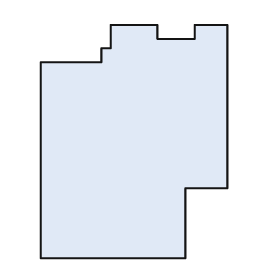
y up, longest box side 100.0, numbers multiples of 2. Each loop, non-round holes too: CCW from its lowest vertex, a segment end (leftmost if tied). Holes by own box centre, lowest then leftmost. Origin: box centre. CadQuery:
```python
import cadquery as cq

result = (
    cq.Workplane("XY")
    .moveTo(-40.0, -50.0)
    .lineTo(22.0, -50.0)
    .lineTo(22.0, -20.0)
    .lineTo(40.0, -20.0)
    .lineTo(40.0, 50.0)
    .lineTo(26.0, 50.0)
    .lineTo(26.0, 44.0)
    .lineTo(10.0, 44.0)
    .lineTo(10.0, 50.0)
    .lineTo(-10.0, 50.0)
    .lineTo(-10.0, 40.0)
    .lineTo(-14.0, 40.0)
    .lineTo(-14.0, 34.0)
    .lineTo(-40.0, 34.0)
    .close()
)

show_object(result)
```